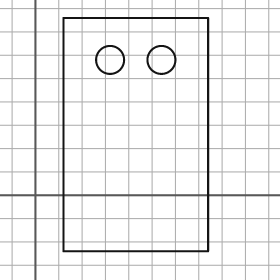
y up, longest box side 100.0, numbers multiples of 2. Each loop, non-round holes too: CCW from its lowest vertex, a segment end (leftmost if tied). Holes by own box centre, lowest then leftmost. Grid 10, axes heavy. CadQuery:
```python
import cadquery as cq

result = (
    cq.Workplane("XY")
    .moveTo(12.0, -24.0)
    .lineTo(74.0, -24.0)
    .lineTo(74.0, 76.0)
    .lineTo(12.0, 76.0)
    .close()
    .moveTo(32.0, 58.0)
    .circle(6.0)
    .moveTo(54.0, 58.0)
    .circle(6.0)
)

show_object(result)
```